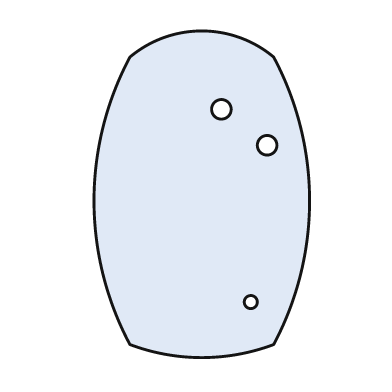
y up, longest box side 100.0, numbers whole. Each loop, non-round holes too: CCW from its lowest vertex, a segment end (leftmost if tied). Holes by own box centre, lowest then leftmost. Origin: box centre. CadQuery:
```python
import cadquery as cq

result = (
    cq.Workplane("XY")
    .moveTo(-22.0, -46.0)
    .threePointArc((0.0, -50.0), (22.0, -46.0))
    .threePointArc((33.0, -2.0), (22.0, 42.0))
    .threePointArc((0.0, 50.0), (-22.0, 42.0))
    .threePointArc((-33.0, -2.0), (-22.0, -46.0))
    .close()
    .moveTo(15.0, -33.0)
    .circle(2.0)
    .moveTo(20.0, 15.0)
    .circle(3.0)
    .moveTo(6.0, 26.0)
    .circle(3.0)
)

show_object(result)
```